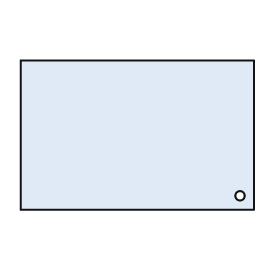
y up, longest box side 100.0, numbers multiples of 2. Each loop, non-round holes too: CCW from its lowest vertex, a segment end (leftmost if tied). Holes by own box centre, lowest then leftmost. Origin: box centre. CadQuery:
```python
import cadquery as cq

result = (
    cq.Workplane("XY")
    .moveTo(-50.0, -32.0)
    .lineTo(50.0, -32.0)
    .lineTo(50.0, 32.0)
    .lineTo(-50.0, 32.0)
    .close()
    .moveTo(44.0, -26.0)
    .circle(2.0)
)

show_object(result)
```